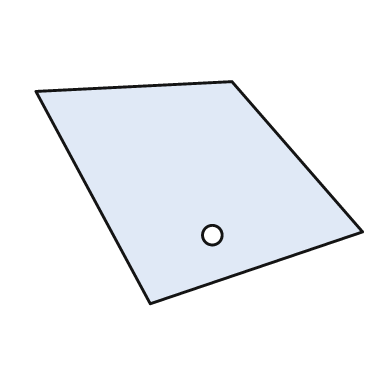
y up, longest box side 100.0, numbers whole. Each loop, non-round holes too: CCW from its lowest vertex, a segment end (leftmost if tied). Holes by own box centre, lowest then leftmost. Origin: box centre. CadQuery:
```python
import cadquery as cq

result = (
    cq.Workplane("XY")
    .moveTo(-15.0, -34.0)
    .lineTo(50.0, -12.0)
    .lineTo(10.0, 34.0)
    .lineTo(-50.0, 31.0)
    .close()
    .moveTo(4.0, -13.0)
    .circle(3.0)
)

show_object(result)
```